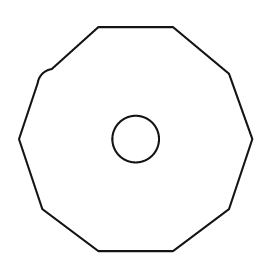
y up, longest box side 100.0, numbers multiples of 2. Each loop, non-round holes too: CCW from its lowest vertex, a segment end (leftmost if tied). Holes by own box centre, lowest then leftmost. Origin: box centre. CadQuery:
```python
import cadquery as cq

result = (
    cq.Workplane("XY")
    .moveTo(-16.0, -48.0)
    .lineTo(16.0, -48.0)
    .lineTo(40.0, -30.0)
    .lineTo(50.0, 0.0)
    .lineTo(40.0, 28.0)
    .lineTo(16.0, 48.0)
    .lineTo(-16.0, 48.0)
    .lineTo(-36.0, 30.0)
    .threePointArc((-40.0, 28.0), (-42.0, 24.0))
    .lineTo(-50.0, 0.0)
    .lineTo(-40.0, -30.0)
    .close()
    .moveTo(0.0, 0.0)
    .circle(10.0)
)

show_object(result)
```